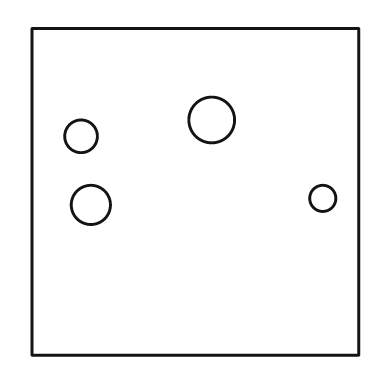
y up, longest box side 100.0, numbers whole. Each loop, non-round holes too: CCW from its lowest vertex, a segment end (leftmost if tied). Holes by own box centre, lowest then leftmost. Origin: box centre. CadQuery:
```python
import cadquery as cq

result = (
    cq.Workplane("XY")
    .moveTo(-50.0, -50.0)
    .lineTo(50.0, -50.0)
    .lineTo(50.0, 50.0)
    .lineTo(-50.0, 50.0)
    .close()
    .moveTo(-32.0, -4.0)
    .circle(6.0)
    .moveTo(39.0, -2.0)
    .circle(4.0)
    .moveTo(-35.0, 17.0)
    .circle(5.0)
    .moveTo(5.0, 22.0)
    .circle(7.0)
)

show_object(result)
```